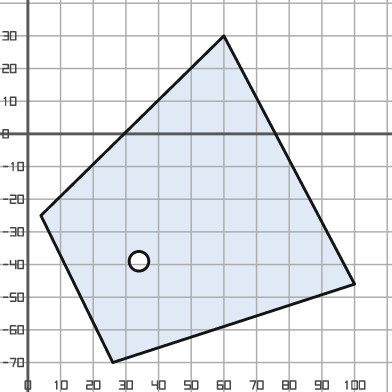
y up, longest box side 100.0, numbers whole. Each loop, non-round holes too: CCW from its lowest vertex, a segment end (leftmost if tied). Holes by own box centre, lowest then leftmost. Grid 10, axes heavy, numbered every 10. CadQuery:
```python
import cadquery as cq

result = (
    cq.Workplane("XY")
    .moveTo(26.0, -70.0)
    .lineTo(100.0, -46.0)
    .lineTo(60.0, 30.0)
    .lineTo(4.0, -25.0)
    .close()
    .moveTo(34.0, -39.0)
    .circle(3.0)
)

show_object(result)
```